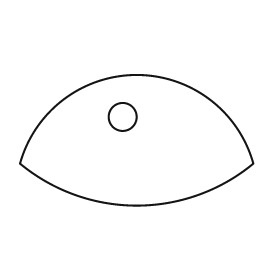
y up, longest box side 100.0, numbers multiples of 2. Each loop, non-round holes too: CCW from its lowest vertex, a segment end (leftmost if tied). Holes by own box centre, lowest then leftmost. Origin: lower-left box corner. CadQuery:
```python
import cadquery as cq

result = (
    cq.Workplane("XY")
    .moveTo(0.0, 18.0)
    .threePointArc((50.0, 0.0), (100.0, 18.0))
    .threePointArc((50.0, 56.0), (0.0, 18.0))
    .close()
    .moveTo(44.0, 38.0)
    .circle(6.0)
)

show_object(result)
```